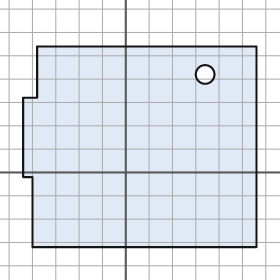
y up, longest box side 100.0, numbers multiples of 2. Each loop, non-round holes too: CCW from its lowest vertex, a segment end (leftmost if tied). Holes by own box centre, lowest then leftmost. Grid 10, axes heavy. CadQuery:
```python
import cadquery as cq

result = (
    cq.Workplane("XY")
    .moveTo(-40.0, -32.0)
    .lineTo(56.0, -32.0)
    .lineTo(56.0, 54.0)
    .lineTo(-38.0, 54.0)
    .lineTo(-38.0, 32.0)
    .lineTo(-44.0, 32.0)
    .lineTo(-44.0, -2.0)
    .lineTo(-40.0, -2.0)
    .close()
    .moveTo(34.0, 42.0)
    .circle(4.0)
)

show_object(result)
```